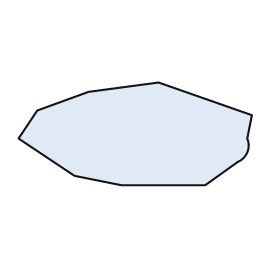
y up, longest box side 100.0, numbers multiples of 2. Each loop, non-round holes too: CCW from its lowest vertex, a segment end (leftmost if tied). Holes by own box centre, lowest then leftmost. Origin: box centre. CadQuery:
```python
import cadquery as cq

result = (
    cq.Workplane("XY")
    .moveTo(-6.0, -22.0)
    .lineTo(30.0, -22.0)
    .lineTo(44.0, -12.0)
    .threePointArc((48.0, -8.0), (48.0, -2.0))
    .lineTo(50.0, 8.0)
    .lineTo(10.0, 22.0)
    .lineTo(-20.0, 18.0)
    .lineTo(-42.0, 10.0)
    .lineTo(-50.0, -2.0)
    .lineTo(-26.0, -18.0)
    .close()
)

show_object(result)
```